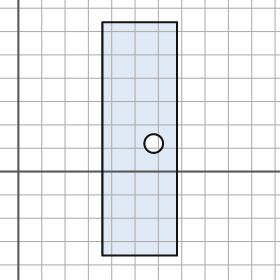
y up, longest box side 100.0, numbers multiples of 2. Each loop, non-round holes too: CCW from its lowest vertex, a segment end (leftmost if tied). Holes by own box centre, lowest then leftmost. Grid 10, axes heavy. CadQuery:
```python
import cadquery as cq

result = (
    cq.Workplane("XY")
    .moveTo(36.0, -36.0)
    .lineTo(68.0, -36.0)
    .lineTo(68.0, 64.0)
    .lineTo(36.0, 64.0)
    .close()
    .moveTo(58.0, 12.0)
    .circle(4.0)
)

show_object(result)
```